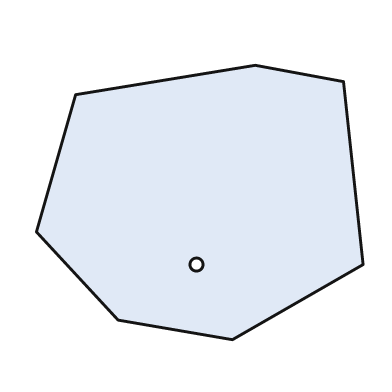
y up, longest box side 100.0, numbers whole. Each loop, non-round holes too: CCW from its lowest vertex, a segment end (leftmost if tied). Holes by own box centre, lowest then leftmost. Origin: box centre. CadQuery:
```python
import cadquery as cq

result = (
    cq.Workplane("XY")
    .moveTo(10.0, -42.0)
    .lineTo(50.0, -19.0)
    .lineTo(44.0, 37.0)
    .lineTo(17.0, 42.0)
    .lineTo(-38.0, 33.0)
    .lineTo(-50.0, -9.0)
    .lineTo(-25.0, -36.0)
    .close()
    .moveTo(-1.0, -19.0)
    .circle(2.0)
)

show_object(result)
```